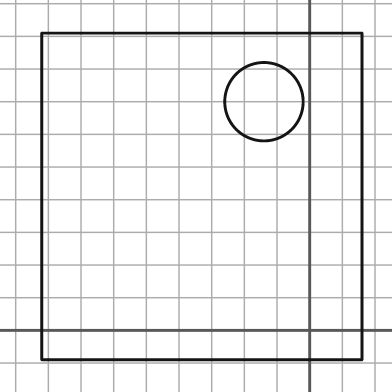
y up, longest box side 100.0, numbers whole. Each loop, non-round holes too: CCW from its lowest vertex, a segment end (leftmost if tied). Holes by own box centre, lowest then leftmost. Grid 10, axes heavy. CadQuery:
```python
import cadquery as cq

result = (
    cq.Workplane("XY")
    .moveTo(-82.0, -9.0)
    .lineTo(16.0, -9.0)
    .lineTo(16.0, 91.0)
    .lineTo(-82.0, 91.0)
    .close()
    .moveTo(-14.0, 70.0)
    .circle(12.0)
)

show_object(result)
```